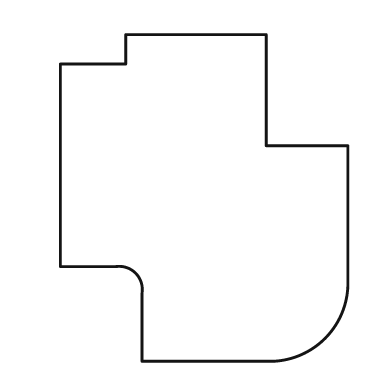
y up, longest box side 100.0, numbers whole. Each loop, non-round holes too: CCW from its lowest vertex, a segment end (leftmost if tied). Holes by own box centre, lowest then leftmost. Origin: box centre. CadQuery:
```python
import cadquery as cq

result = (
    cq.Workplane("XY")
    .moveTo(-19.0, -50.0)
    .lineTo(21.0, -50.0)
    .threePointArc((37.0, -43.0), (44.0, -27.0))
    .lineTo(44.0, 16.0)
    .lineTo(19.0, 16.0)
    .lineTo(19.0, 50.0)
    .lineTo(-24.0, 50.0)
    .lineTo(-24.0, 41.0)
    .lineTo(-44.0, 41.0)
    .lineTo(-44.0, -21.0)
    .lineTo(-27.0, -21.0)
    .threePointArc((-21.0, -23.0), (-19.0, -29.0))
    .close()
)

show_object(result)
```